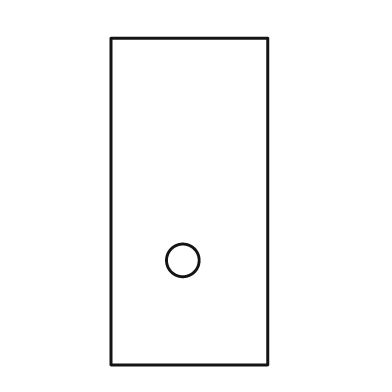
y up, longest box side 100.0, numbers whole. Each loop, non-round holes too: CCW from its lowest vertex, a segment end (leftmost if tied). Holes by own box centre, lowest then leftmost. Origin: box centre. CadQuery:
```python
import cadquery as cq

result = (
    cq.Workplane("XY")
    .moveTo(-24.0, -50.0)
    .lineTo(24.0, -50.0)
    .lineTo(24.0, 50.0)
    .lineTo(-24.0, 50.0)
    .close()
    .moveTo(-2.0, -18.0)
    .circle(5.0)
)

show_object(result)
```